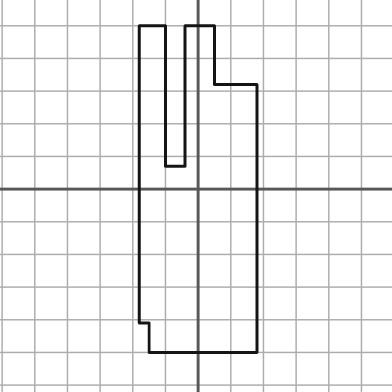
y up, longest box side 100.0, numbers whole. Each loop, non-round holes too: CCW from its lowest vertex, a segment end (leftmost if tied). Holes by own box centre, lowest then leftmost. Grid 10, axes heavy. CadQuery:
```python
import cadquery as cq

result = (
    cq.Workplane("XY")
    .moveTo(-15.0, -50.0)
    .lineTo(18.0, -50.0)
    .lineTo(18.0, 32.0)
    .lineTo(5.0, 32.0)
    .lineTo(5.0, 50.0)
    .lineTo(-4.0, 50.0)
    .lineTo(-4.0, 7.0)
    .lineTo(-10.0, 7.0)
    .lineTo(-10.0, 50.0)
    .lineTo(-18.0, 50.0)
    .lineTo(-18.0, -41.0)
    .lineTo(-15.0, -41.0)
    .close()
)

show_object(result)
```